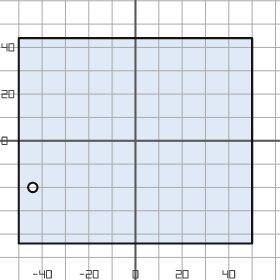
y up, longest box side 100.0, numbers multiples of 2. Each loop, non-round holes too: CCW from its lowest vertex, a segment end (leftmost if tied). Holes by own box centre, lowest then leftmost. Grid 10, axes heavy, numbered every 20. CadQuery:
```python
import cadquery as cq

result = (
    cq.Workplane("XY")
    .moveTo(-50.0, -44.0)
    .lineTo(50.0, -44.0)
    .lineTo(50.0, 44.0)
    .lineTo(-50.0, 44.0)
    .close()
    .moveTo(-44.0, -20.0)
    .circle(2.0)
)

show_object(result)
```